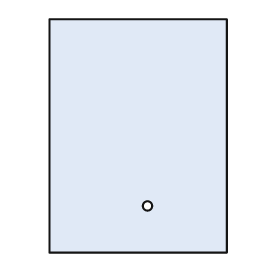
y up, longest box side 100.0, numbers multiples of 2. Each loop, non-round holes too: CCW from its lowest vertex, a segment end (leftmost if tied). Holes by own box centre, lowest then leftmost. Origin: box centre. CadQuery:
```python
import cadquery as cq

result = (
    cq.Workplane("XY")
    .moveTo(-38.0, -50.0)
    .lineTo(38.0, -50.0)
    .lineTo(38.0, 50.0)
    .lineTo(-38.0, 50.0)
    .close()
    .moveTo(4.0, -30.0)
    .circle(2.0)
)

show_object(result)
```